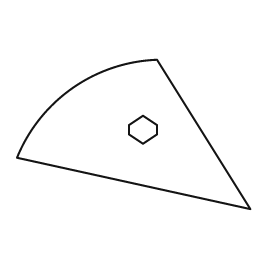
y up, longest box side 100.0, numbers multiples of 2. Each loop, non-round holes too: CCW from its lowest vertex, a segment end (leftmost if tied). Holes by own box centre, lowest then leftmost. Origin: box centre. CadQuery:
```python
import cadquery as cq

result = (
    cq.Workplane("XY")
    .moveTo(50.0, -32.0)
    .lineTo(10.0, 32.0)
    .threePointArc((-26.0, 20.0), (-50.0, -10.0))
    .close()
    .moveTo(4.0, -4.0)
    .lineTo(10.0, 0.0)
    .lineTo(10.0, 4.0)
    .lineTo(4.0, 8.0)
    .lineTo(-2.0, 4.0)
    .lineTo(-2.0, 0.0)
    .close()
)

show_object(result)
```